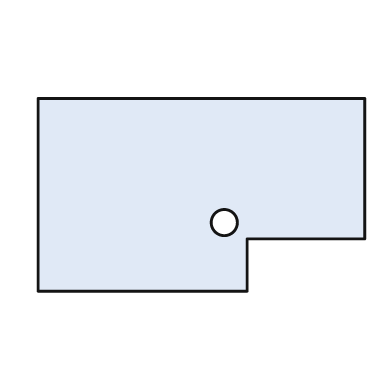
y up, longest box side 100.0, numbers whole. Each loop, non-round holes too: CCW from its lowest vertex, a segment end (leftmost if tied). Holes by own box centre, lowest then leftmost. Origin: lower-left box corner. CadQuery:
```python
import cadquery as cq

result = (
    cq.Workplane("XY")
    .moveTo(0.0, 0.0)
    .lineTo(64.0, 0.0)
    .lineTo(64.0, 16.0)
    .lineTo(100.0, 16.0)
    .lineTo(100.0, 59.0)
    .lineTo(0.0, 59.0)
    .close()
    .moveTo(57.0, 21.0)
    .circle(4.0)
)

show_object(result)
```